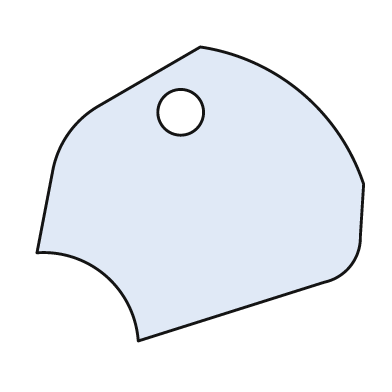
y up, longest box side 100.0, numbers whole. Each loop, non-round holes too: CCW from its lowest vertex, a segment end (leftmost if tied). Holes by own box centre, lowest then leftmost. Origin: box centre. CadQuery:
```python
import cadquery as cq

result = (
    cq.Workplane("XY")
    .moveTo(-19.0, -45.0)
    .lineTo(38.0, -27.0)
    .threePointArc((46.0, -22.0), (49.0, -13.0))
    .lineTo(50.0, 3.0)
    .threePointArc((31.0, 31.0), (0.0, 45.0))
    .lineTo(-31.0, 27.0)
    .threePointArc((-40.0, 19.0), (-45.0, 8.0))
    .lineTo(-50.0, -18.0)
    .threePointArc((-29.0, -25.0), (-19.0, -45.0))
    .close()
    .moveTo(-6.0, 25.0)
    .circle(7.0)
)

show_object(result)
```